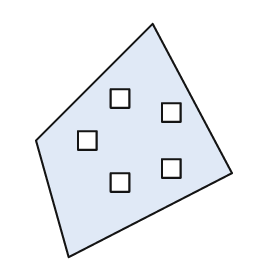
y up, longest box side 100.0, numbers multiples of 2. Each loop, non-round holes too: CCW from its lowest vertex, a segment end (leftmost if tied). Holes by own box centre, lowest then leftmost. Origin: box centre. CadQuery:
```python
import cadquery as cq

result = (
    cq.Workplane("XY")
    .moveTo(-28.0, -50.0)
    .lineTo(42.0, -14.0)
    .lineTo(8.0, 50.0)
    .lineTo(-42.0, 0.0)
    .close()
    .moveTo(-10.0, -22.0)
    .lineTo(-2.0, -22.0)
    .lineTo(-2.0, -14.0)
    .lineTo(-10.0, -14.0)
    .close()
    .moveTo(12.0, -16.0)
    .lineTo(20.0, -16.0)
    .lineTo(20.0, -8.0)
    .lineTo(12.0, -8.0)
    .close()
    .moveTo(-24.0, -4.0)
    .lineTo(-16.0, -4.0)
    .lineTo(-16.0, 4.0)
    .lineTo(-24.0, 4.0)
    .close()
    .moveTo(12.0, 8.0)
    .lineTo(20.0, 8.0)
    .lineTo(20.0, 16.0)
    .lineTo(12.0, 16.0)
    .close()
    .moveTo(-10.0, 14.0)
    .lineTo(-2.0, 14.0)
    .lineTo(-2.0, 22.0)
    .lineTo(-10.0, 22.0)
    .close()
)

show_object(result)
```